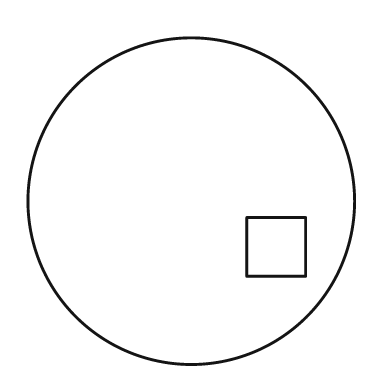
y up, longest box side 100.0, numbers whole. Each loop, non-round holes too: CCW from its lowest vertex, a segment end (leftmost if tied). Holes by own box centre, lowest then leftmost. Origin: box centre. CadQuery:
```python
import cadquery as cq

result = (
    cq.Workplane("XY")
    .moveTo(0.0, 0.0)
    .circle(50.0)
    .moveTo(17.0, -23.0)
    .lineTo(35.0, -23.0)
    .lineTo(35.0, -5.0)
    .lineTo(17.0, -5.0)
    .close()
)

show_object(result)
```